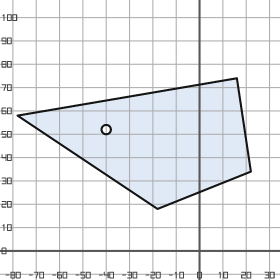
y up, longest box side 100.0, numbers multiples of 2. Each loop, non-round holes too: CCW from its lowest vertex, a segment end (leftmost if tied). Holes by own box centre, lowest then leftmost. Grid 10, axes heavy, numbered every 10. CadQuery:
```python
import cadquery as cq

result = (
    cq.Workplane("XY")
    .moveTo(-18.0, 18.0)
    .lineTo(22.0, 34.0)
    .lineTo(16.0, 74.0)
    .lineTo(-78.0, 58.0)
    .close()
    .moveTo(-40.0, 52.0)
    .circle(2.0)
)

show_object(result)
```